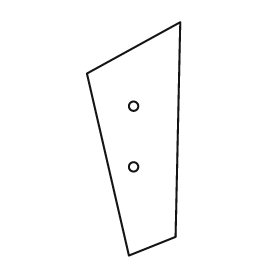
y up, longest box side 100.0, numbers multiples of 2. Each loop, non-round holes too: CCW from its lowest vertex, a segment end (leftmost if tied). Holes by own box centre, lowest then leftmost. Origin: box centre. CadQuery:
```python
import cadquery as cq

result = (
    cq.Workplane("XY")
    .moveTo(-2.0, -50.0)
    .lineTo(18.0, -42.0)
    .lineTo(20.0, 50.0)
    .lineTo(-20.0, 28.0)
    .close()
    .moveTo(0.0, -12.0)
    .circle(2.0)
    .moveTo(0.0, 14.0)
    .circle(2.0)
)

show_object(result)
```